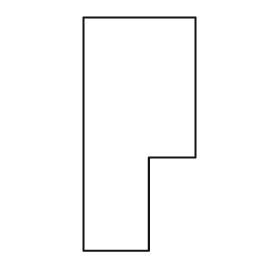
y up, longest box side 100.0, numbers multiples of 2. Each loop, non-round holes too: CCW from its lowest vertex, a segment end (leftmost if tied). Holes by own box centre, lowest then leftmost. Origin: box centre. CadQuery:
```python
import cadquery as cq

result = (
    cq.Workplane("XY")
    .moveTo(-24.0, -50.0)
    .lineTo(4.0, -50.0)
    .lineTo(4.0, -10.0)
    .lineTo(24.0, -10.0)
    .lineTo(24.0, 50.0)
    .lineTo(-24.0, 50.0)
    .close()
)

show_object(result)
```